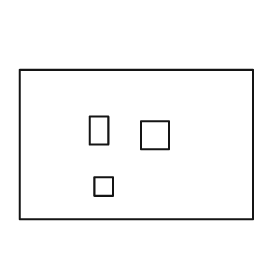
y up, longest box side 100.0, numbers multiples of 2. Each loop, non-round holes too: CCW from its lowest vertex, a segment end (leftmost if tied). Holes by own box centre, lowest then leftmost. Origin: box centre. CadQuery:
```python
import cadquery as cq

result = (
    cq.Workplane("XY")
    .moveTo(-50.0, -32.0)
    .lineTo(50.0, -32.0)
    .lineTo(50.0, 32.0)
    .lineTo(-50.0, 32.0)
    .close()
    .moveTo(-18.0, -22.0)
    .lineTo(-10.0, -22.0)
    .lineTo(-10.0, -14.0)
    .lineTo(-18.0, -14.0)
    .close()
    .moveTo(2.0, -2.0)
    .lineTo(14.0, -2.0)
    .lineTo(14.0, 10.0)
    .lineTo(2.0, 10.0)
    .close()
    .moveTo(-20.0, 0.0)
    .lineTo(-12.0, 0.0)
    .lineTo(-12.0, 12.0)
    .lineTo(-20.0, 12.0)
    .close()
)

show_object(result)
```